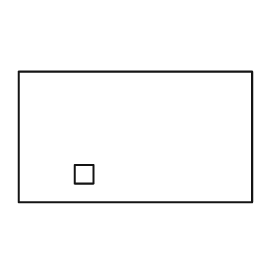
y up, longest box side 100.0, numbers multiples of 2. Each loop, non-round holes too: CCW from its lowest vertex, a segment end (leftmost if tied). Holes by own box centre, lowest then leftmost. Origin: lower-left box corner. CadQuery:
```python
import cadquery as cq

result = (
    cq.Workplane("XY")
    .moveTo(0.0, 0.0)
    .lineTo(100.0, 0.0)
    .lineTo(100.0, 56.0)
    .lineTo(0.0, 56.0)
    .close()
    .moveTo(24.0, 8.0)
    .lineTo(32.0, 8.0)
    .lineTo(32.0, 16.0)
    .lineTo(24.0, 16.0)
    .close()
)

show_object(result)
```